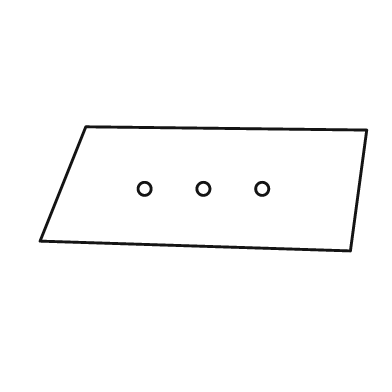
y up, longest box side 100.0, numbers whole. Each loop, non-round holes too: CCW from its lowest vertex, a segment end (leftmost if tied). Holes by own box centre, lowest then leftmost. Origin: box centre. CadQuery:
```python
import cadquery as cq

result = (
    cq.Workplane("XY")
    .moveTo(45.0, -19.0)
    .lineTo(50.0, 18.0)
    .lineTo(-36.0, 19.0)
    .lineTo(-50.0, -16.0)
    .close()
    .moveTo(-18.0, 0.0)
    .circle(2.0)
    .moveTo(0.0, 0.0)
    .circle(2.0)
    .moveTo(18.0, 0.0)
    .circle(2.0)
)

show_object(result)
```